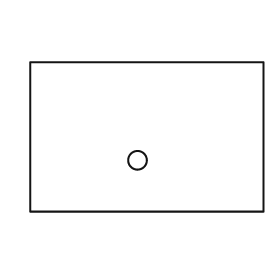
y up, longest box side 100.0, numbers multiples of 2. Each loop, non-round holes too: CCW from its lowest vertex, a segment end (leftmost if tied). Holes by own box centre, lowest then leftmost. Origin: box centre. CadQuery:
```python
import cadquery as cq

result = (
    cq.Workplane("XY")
    .moveTo(-50.0, -32.0)
    .lineTo(50.0, -32.0)
    .lineTo(50.0, 32.0)
    .lineTo(-50.0, 32.0)
    .close()
    .moveTo(-4.0, -10.0)
    .circle(4.0)
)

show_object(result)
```